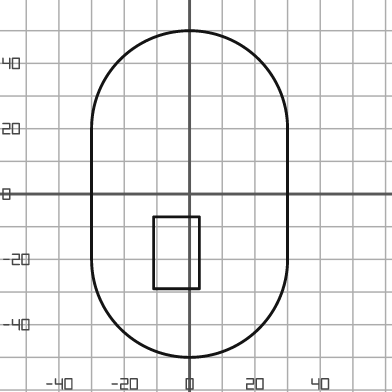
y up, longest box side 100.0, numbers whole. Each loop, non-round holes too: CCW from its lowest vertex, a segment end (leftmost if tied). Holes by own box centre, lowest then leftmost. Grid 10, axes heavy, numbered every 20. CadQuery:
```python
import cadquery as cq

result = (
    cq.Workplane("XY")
    .moveTo(-30.0, -20.0)
    .threePointArc((0.0, -50.0), (30.0, -20.0))
    .lineTo(30.0, 20.0)
    .threePointArc((0.0, 50.0), (-30.0, 20.0))
    .close()
    .moveTo(-11.0, -29.0)
    .lineTo(3.0, -29.0)
    .lineTo(3.0, -7.0)
    .lineTo(-11.0, -7.0)
    .close()
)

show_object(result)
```